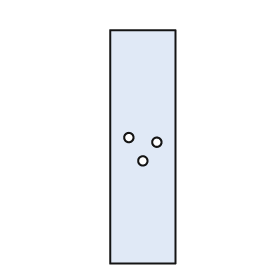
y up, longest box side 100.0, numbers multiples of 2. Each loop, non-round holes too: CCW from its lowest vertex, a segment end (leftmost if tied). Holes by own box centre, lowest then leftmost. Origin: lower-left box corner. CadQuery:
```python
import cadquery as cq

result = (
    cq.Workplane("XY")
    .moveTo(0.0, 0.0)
    .lineTo(28.0, 0.0)
    .lineTo(28.0, 100.0)
    .lineTo(0.0, 100.0)
    .close()
    .moveTo(14.0, 44.0)
    .circle(2.0)
    .moveTo(20.0, 52.0)
    .circle(2.0)
    .moveTo(8.0, 54.0)
    .circle(2.0)
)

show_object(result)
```